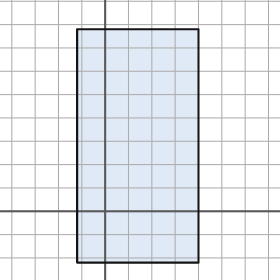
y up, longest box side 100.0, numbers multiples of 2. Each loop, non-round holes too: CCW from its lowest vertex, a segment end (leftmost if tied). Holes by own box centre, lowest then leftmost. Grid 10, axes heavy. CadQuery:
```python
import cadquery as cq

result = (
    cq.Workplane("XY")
    .moveTo(-12.0, -22.0)
    .lineTo(40.0, -22.0)
    .lineTo(40.0, 78.0)
    .lineTo(-12.0, 78.0)
    .close()
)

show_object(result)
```